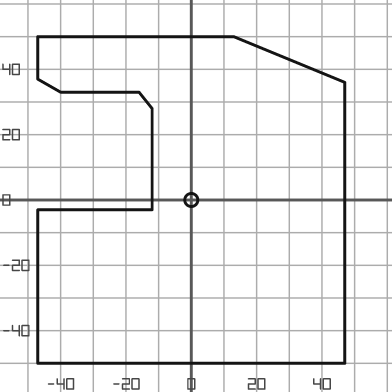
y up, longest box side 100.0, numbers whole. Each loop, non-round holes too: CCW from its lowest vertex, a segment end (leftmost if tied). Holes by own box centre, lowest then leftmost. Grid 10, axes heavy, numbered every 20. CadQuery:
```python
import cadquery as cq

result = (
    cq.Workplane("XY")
    .moveTo(-47.0, -50.0)
    .lineTo(47.0, -50.0)
    .lineTo(47.0, 36.0)
    .lineTo(13.0, 50.0)
    .lineTo(-47.0, 50.0)
    .lineTo(-47.0, 37.0)
    .lineTo(-40.0, 33.0)
    .lineTo(-16.0, 33.0)
    .lineTo(-12.0, 28.0)
    .lineTo(-12.0, -3.0)
    .lineTo(-47.0, -3.0)
    .close()
    .moveTo(0.0, 0.0)
    .circle(2.0)
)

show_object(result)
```